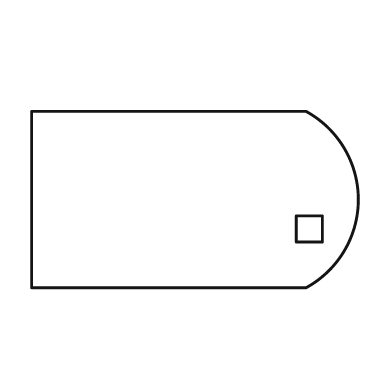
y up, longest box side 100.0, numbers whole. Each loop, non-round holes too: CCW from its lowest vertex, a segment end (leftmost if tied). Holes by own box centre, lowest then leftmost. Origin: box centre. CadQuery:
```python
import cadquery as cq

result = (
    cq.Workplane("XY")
    .moveTo(-50.0, -27.0)
    .lineTo(34.0, -27.0)
    .threePointArc((50.0, 0.0), (34.0, 27.0))
    .lineTo(-50.0, 27.0)
    .close()
    .moveTo(31.0, -13.0)
    .lineTo(39.0, -13.0)
    .lineTo(39.0, -5.0)
    .lineTo(31.0, -5.0)
    .close()
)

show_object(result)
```